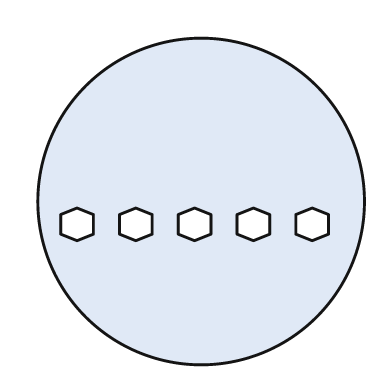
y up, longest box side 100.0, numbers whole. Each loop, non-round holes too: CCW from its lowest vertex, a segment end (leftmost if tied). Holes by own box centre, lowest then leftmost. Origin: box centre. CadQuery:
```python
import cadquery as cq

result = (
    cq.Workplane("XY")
    .moveTo(0.0, 0.0)
    .circle(50.0)
    .moveTo(-38.0, -12.0)
    .lineTo(-33.0, -10.0)
    .lineTo(-33.0, -4.0)
    .lineTo(-38.0, -2.0)
    .lineTo(-43.0, -4.0)
    .lineTo(-43.0, -10.0)
    .close()
    .moveTo(-20.0, -12.0)
    .lineTo(-15.0, -10.0)
    .lineTo(-15.0, -4.0)
    .lineTo(-20.0, -2.0)
    .lineTo(-25.0, -4.0)
    .lineTo(-25.0, -10.0)
    .close()
    .moveTo(-2.0, -12.0)
    .lineTo(3.0, -10.0)
    .lineTo(3.0, -4.0)
    .lineTo(-2.0, -2.0)
    .lineTo(-7.0, -4.0)
    .lineTo(-7.0, -10.0)
    .close()
    .moveTo(16.0, -12.0)
    .lineTo(21.0, -10.0)
    .lineTo(21.0, -4.0)
    .lineTo(16.0, -2.0)
    .lineTo(11.0, -4.0)
    .lineTo(11.0, -10.0)
    .close()
    .moveTo(34.0, -12.0)
    .lineTo(39.0, -10.0)
    .lineTo(39.0, -4.0)
    .lineTo(34.0, -2.0)
    .lineTo(29.0, -4.0)
    .lineTo(29.0, -10.0)
    .close()
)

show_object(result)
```